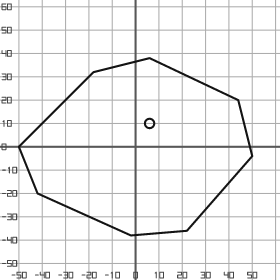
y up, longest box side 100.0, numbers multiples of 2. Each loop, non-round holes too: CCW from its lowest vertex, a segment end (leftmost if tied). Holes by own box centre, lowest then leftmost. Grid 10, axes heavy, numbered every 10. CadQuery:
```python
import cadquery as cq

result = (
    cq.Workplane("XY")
    .moveTo(-2.0, -38.0)
    .lineTo(22.0, -36.0)
    .lineTo(50.0, -4.0)
    .lineTo(44.0, 20.0)
    .lineTo(6.0, 38.0)
    .lineTo(-18.0, 32.0)
    .lineTo(-50.0, 0.0)
    .lineTo(-42.0, -20.0)
    .close()
    .moveTo(6.0, 10.0)
    .circle(2.0)
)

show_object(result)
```